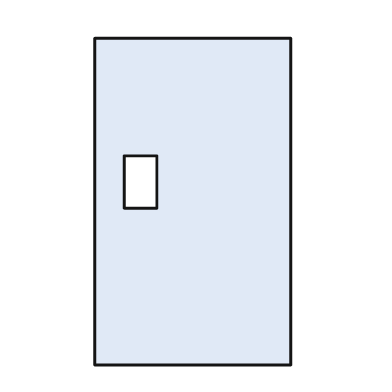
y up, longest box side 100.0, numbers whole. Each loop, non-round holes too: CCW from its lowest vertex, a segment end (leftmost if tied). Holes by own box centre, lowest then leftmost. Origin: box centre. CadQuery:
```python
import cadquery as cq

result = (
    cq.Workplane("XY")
    .moveTo(-30.0, -50.0)
    .lineTo(30.0, -50.0)
    .lineTo(30.0, 50.0)
    .lineTo(-30.0, 50.0)
    .close()
    .moveTo(-21.0, -2.0)
    .lineTo(-11.0, -2.0)
    .lineTo(-11.0, 14.0)
    .lineTo(-21.0, 14.0)
    .close()
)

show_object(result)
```